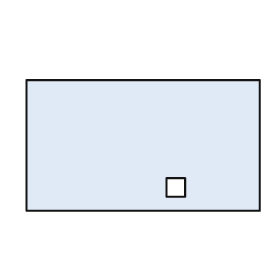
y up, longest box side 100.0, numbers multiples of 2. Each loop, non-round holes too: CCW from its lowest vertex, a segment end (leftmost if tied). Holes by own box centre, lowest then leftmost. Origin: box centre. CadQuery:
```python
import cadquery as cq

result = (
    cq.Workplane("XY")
    .moveTo(-50.0, -28.0)
    .lineTo(50.0, -28.0)
    .lineTo(50.0, 28.0)
    .lineTo(-50.0, 28.0)
    .close()
    .moveTo(10.0, -22.0)
    .lineTo(18.0, -22.0)
    .lineTo(18.0, -14.0)
    .lineTo(10.0, -14.0)
    .close()
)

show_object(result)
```